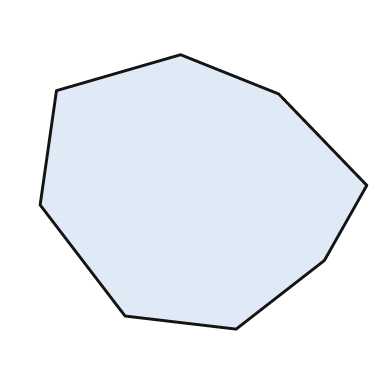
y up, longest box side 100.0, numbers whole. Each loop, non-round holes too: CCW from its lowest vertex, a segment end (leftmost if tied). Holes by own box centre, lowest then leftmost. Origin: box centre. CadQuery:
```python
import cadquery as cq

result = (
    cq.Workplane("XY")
    .moveTo(10.0, -42.0)
    .lineTo(37.0, -21.0)
    .lineTo(50.0, 2.0)
    .lineTo(23.0, 30.0)
    .lineTo(-7.0, 42.0)
    .lineTo(-45.0, 31.0)
    .lineTo(-50.0, -4.0)
    .lineTo(-24.0, -38.0)
    .close()
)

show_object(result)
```